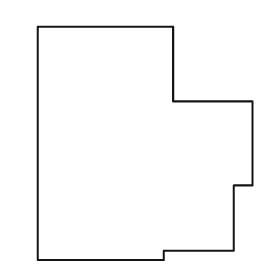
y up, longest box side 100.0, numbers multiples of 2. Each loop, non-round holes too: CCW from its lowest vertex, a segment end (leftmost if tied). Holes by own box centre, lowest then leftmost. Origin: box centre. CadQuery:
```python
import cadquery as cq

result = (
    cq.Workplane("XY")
    .moveTo(-46.0, -50.0)
    .lineTo(8.0, -50.0)
    .lineTo(8.0, -46.0)
    .lineTo(38.0, -46.0)
    .lineTo(38.0, -18.0)
    .lineTo(46.0, -18.0)
    .lineTo(46.0, 18.0)
    .lineTo(12.0, 18.0)
    .lineTo(12.0, 50.0)
    .lineTo(-46.0, 50.0)
    .close()
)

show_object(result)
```